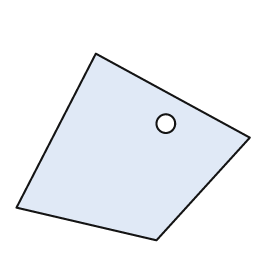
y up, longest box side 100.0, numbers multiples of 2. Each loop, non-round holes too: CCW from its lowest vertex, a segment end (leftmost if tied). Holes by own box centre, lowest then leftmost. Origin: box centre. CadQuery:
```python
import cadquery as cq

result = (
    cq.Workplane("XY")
    .moveTo(10.0, -40.0)
    .lineTo(50.0, 4.0)
    .lineTo(-16.0, 40.0)
    .lineTo(-50.0, -26.0)
    .close()
    .moveTo(14.0, 10.0)
    .circle(4.0)
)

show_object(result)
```